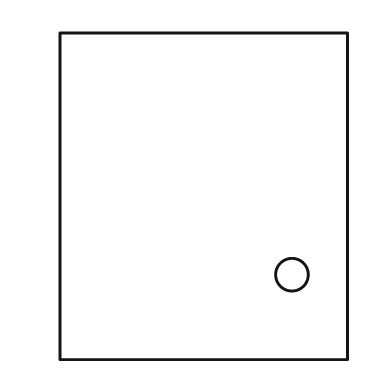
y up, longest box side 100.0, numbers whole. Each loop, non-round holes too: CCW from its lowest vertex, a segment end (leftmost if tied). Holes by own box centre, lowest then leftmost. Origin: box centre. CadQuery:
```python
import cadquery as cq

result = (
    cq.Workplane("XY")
    .moveTo(-44.0, -50.0)
    .lineTo(44.0, -50.0)
    .lineTo(44.0, 50.0)
    .lineTo(-44.0, 50.0)
    .close()
    .moveTo(27.0, -24.0)
    .circle(5.0)
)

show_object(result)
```